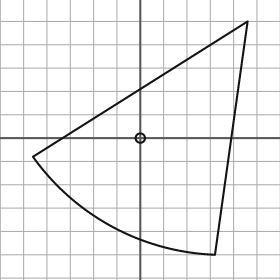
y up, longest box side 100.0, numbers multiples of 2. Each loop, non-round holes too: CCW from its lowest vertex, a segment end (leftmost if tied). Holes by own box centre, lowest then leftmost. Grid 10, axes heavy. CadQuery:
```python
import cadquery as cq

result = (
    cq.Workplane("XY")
    .moveTo(32.0, -50.0)
    .lineTo(46.0, 50.0)
    .lineTo(-46.0, -8.0)
    .threePointArc((-12.0, -38.0), (32.0, -50.0))
    .close()
    .moveTo(0.0, 0.0)
    .circle(2.0)
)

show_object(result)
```